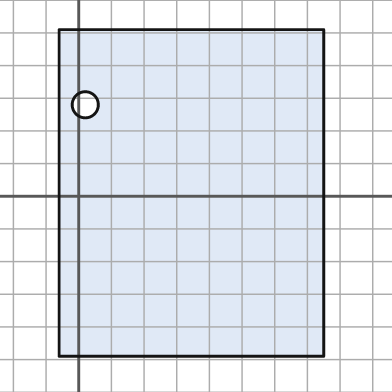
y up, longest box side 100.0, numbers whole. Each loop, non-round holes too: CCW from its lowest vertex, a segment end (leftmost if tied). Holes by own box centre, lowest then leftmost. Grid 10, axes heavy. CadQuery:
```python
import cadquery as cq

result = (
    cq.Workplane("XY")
    .moveTo(-6.0, -49.0)
    .lineTo(75.0, -49.0)
    .lineTo(75.0, 51.0)
    .lineTo(-6.0, 51.0)
    .close()
    .moveTo(2.0, 28.0)
    .circle(4.0)
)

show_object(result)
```